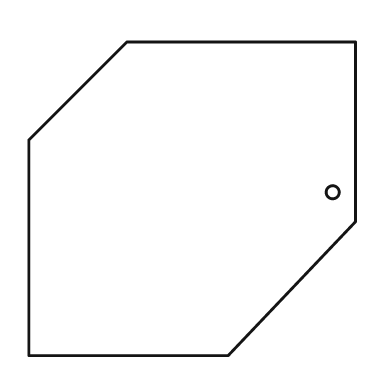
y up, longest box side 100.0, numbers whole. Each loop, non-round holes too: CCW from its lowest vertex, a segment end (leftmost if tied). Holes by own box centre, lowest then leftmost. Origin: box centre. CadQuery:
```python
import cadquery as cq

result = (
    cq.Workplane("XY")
    .moveTo(-50.0, -48.0)
    .lineTo(11.0, -48.0)
    .lineTo(50.0, -7.0)
    .lineTo(50.0, 48.0)
    .lineTo(-20.0, 48.0)
    .lineTo(-50.0, 18.0)
    .close()
    .moveTo(43.0, 2.0)
    .circle(2.0)
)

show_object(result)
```